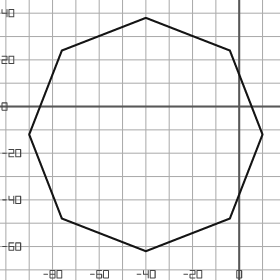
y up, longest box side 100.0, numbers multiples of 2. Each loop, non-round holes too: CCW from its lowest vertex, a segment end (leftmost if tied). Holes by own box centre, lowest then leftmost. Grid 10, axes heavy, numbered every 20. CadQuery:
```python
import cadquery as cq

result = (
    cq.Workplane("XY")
    .moveTo(-40.0, -62.0)
    .lineTo(-4.0, -48.0)
    .lineTo(10.0, -12.0)
    .lineTo(-4.0, 24.0)
    .lineTo(-40.0, 38.0)
    .lineTo(-76.0, 24.0)
    .lineTo(-90.0, -12.0)
    .lineTo(-76.0, -48.0)
    .close()
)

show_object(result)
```